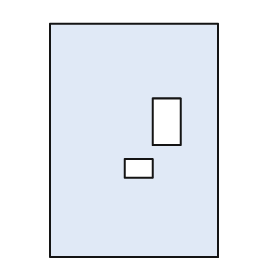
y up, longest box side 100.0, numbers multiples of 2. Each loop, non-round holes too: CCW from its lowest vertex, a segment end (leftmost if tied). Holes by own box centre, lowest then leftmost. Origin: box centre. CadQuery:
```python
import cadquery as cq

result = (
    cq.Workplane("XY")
    .moveTo(-36.0, -50.0)
    .lineTo(36.0, -50.0)
    .lineTo(36.0, 50.0)
    .lineTo(-36.0, 50.0)
    .close()
    .moveTo(-4.0, -16.0)
    .lineTo(8.0, -16.0)
    .lineTo(8.0, -8.0)
    .lineTo(-4.0, -8.0)
    .close()
    .moveTo(8.0, -2.0)
    .lineTo(20.0, -2.0)
    .lineTo(20.0, 18.0)
    .lineTo(8.0, 18.0)
    .close()
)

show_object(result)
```